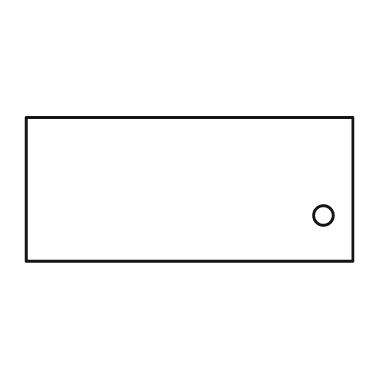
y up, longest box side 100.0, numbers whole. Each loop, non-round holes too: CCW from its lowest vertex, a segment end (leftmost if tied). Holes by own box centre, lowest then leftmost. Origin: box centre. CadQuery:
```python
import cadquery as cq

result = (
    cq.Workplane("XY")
    .moveTo(-50.0, -22.0)
    .lineTo(50.0, -22.0)
    .lineTo(50.0, 22.0)
    .lineTo(-50.0, 22.0)
    .close()
    .moveTo(41.0, -8.0)
    .circle(3.0)
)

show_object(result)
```